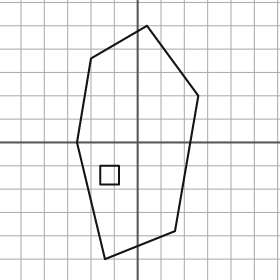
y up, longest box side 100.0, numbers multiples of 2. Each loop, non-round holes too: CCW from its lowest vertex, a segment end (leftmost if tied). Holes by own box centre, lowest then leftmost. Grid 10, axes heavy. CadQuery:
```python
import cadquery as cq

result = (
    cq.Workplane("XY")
    .moveTo(-14.0, -50.0)
    .lineTo(16.0, -38.0)
    .lineTo(26.0, 20.0)
    .lineTo(4.0, 50.0)
    .lineTo(-20.0, 36.0)
    .lineTo(-26.0, 0.0)
    .close()
    .moveTo(-16.0, -18.0)
    .lineTo(-8.0, -18.0)
    .lineTo(-8.0, -10.0)
    .lineTo(-16.0, -10.0)
    .close()
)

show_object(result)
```